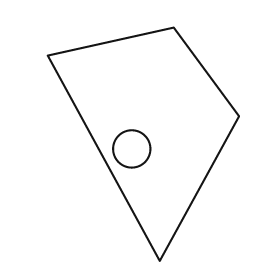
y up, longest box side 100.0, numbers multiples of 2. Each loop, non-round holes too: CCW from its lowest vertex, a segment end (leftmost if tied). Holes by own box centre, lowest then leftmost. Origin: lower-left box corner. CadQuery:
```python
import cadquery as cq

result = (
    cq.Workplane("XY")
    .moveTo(48.0, 0.0)
    .lineTo(82.0, 62.0)
    .lineTo(54.0, 100.0)
    .lineTo(0.0, 88.0)
    .close()
    .moveTo(36.0, 48.0)
    .circle(8.0)
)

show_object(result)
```